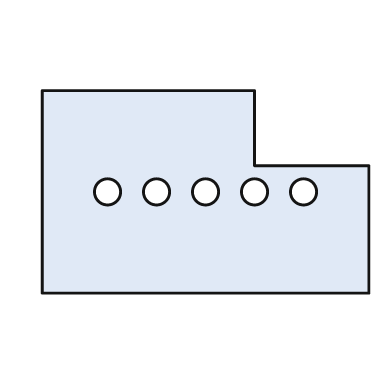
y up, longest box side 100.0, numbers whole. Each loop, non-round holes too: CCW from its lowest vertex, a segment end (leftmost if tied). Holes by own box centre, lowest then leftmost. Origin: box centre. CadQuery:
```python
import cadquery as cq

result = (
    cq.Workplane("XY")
    .moveTo(-50.0, -31.0)
    .lineTo(50.0, -31.0)
    .lineTo(50.0, 8.0)
    .lineTo(15.0, 8.0)
    .lineTo(15.0, 31.0)
    .lineTo(-50.0, 31.0)
    .close()
    .moveTo(-30.0, 0.0)
    .circle(4.0)
    .moveTo(-15.0, 0.0)
    .circle(4.0)
    .moveTo(0.0, 0.0)
    .circle(4.0)
    .moveTo(15.0, 0.0)
    .circle(4.0)
    .moveTo(30.0, 0.0)
    .circle(4.0)
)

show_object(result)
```